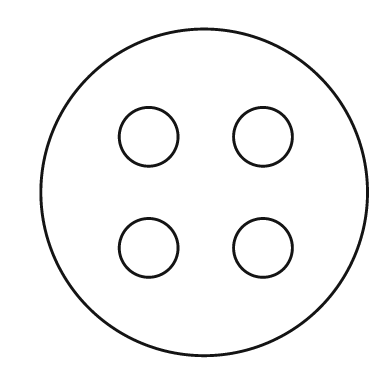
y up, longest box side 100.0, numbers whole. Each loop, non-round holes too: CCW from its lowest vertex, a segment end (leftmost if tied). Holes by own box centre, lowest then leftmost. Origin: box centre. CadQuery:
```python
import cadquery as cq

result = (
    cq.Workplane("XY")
    .moveTo(0.0, 0.0)
    .circle(50.0)
    .moveTo(-17.0, -17.0)
    .circle(9.0)
    .moveTo(18.0, -17.0)
    .circle(9.0)
    .moveTo(-17.0, 17.0)
    .circle(9.0)
    .moveTo(18.0, 17.0)
    .circle(9.0)
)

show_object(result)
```